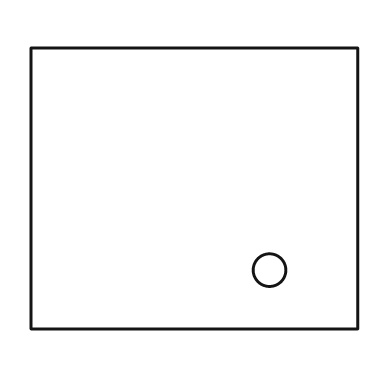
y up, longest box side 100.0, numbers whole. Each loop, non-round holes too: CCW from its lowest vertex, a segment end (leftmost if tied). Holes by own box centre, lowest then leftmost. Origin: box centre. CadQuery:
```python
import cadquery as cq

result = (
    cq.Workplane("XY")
    .moveTo(-50.0, -43.0)
    .lineTo(50.0, -43.0)
    .lineTo(50.0, 43.0)
    .lineTo(-50.0, 43.0)
    .close()
    .moveTo(23.0, -25.0)
    .circle(5.0)
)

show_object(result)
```